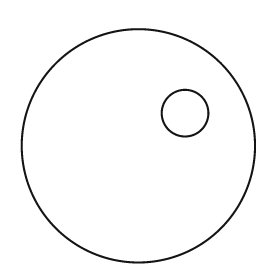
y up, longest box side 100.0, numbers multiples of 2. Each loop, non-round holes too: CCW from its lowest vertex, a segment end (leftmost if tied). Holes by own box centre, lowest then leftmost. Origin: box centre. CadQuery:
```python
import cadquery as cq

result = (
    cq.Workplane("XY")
    .moveTo(0.0, 0.0)
    .circle(50.0)
    .moveTo(20.0, 14.0)
    .circle(10.0)
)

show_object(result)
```